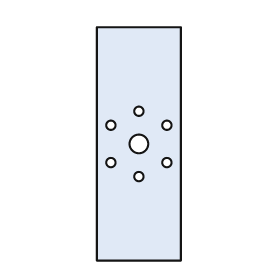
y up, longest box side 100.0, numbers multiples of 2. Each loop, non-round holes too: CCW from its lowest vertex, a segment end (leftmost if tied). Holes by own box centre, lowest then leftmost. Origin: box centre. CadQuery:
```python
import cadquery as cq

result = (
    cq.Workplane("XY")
    .moveTo(-18.0, -50.0)
    .lineTo(18.0, -50.0)
    .lineTo(18.0, 50.0)
    .lineTo(-18.0, 50.0)
    .close()
    .moveTo(0.0, -14.0)
    .circle(2.0)
    .moveTo(-12.0, -8.0)
    .circle(2.0)
    .moveTo(12.0, -8.0)
    .circle(2.0)
    .moveTo(0.0, 0.0)
    .circle(4.0)
    .moveTo(-12.0, 8.0)
    .circle(2.0)
    .moveTo(12.0, 8.0)
    .circle(2.0)
    .moveTo(0.0, 14.0)
    .circle(2.0)
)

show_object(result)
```